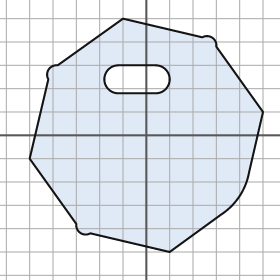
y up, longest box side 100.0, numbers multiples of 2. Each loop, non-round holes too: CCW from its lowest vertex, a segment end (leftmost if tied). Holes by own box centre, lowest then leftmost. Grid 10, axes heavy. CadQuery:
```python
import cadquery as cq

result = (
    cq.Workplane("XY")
    .moveTo(10.0, -50.0)
    .lineTo(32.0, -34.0)
    .threePointArc((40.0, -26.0), (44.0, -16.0))
    .lineTo(50.0, 10.0)
    .lineTo(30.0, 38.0)
    .threePointArc((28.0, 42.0), (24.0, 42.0))
    .lineTo(-10.0, 50.0)
    .lineTo(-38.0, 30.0)
    .threePointArc((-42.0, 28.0), (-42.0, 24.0))
    .lineTo(-50.0, -10.0)
    .lineTo(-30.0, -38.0)
    .threePointArc((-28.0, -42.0), (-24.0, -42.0))
    .close()
    .moveTo(-12.0, 18.0)
    .lineTo(4.0, 18.0)
    .threePointArc((10.0, 24.0), (4.0, 30.0))
    .lineTo(-12.0, 30.0)
    .threePointArc((-18.0, 24.0), (-12.0, 18.0))
    .close()
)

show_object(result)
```